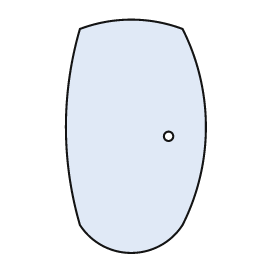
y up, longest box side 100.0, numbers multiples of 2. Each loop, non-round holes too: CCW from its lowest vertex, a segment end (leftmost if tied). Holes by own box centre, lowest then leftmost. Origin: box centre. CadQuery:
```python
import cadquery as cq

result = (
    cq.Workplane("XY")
    .moveTo(-24.0, -38.0)
    .threePointArc((-2.0, -50.0), (20.0, -38.0))
    .threePointArc((30.0, 4.0), (20.0, 46.0))
    .threePointArc((-2.0, 50.0), (-24.0, 46.0))
    .threePointArc((-30.0, 4.0), (-24.0, -38.0))
    .close()
    .moveTo(14.0, 0.0)
    .circle(2.0)
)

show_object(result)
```